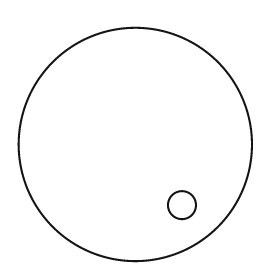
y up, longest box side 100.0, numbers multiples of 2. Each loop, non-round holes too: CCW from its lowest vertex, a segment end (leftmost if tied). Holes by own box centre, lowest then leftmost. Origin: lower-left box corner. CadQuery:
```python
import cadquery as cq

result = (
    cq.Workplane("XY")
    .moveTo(50.0, 50.0)
    .circle(50.0)
    .moveTo(70.0, 24.0)
    .circle(6.0)
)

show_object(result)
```